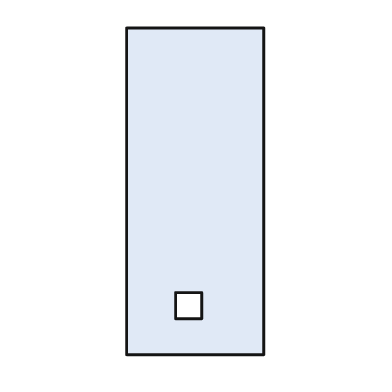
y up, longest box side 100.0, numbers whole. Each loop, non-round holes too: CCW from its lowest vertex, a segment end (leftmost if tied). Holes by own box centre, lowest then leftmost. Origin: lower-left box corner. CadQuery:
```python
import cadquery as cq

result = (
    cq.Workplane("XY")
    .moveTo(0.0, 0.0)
    .lineTo(42.0, 0.0)
    .lineTo(42.0, 100.0)
    .lineTo(0.0, 100.0)
    .close()
    .moveTo(15.0, 11.0)
    .lineTo(23.0, 11.0)
    .lineTo(23.0, 19.0)
    .lineTo(15.0, 19.0)
    .close()
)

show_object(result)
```